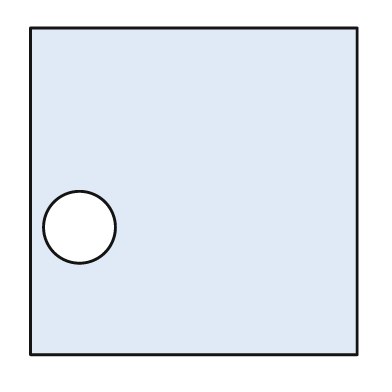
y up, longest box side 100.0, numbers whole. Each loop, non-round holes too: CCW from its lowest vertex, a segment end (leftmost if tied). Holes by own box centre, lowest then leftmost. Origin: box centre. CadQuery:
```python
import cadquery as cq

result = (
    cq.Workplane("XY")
    .moveTo(-50.0, -50.0)
    .lineTo(50.0, -50.0)
    .lineTo(50.0, 50.0)
    .lineTo(-50.0, 50.0)
    .close()
    .moveTo(-35.0, -11.0)
    .circle(11.0)
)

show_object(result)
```